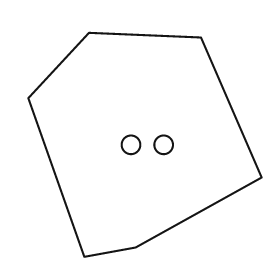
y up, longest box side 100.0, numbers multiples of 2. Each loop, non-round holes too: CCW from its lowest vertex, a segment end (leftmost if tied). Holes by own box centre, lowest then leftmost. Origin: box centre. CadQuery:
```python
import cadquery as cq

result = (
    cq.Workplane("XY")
    .moveTo(-26.0, -48.0)
    .lineTo(-4.0, -44.0)
    .lineTo(50.0, -14.0)
    .lineTo(24.0, 46.0)
    .lineTo(-24.0, 48.0)
    .lineTo(-50.0, 20.0)
    .close()
    .moveTo(-6.0, 0.0)
    .circle(4.0)
    .moveTo(8.0, 0.0)
    .circle(4.0)
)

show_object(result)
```